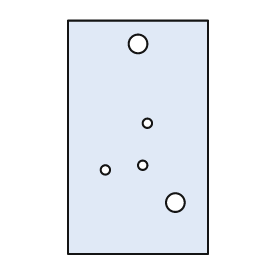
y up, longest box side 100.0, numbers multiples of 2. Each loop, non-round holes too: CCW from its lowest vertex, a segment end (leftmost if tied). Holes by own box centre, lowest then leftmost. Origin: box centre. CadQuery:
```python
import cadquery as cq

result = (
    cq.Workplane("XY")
    .moveTo(-30.0, -50.0)
    .lineTo(30.0, -50.0)
    .lineTo(30.0, 50.0)
    .lineTo(-30.0, 50.0)
    .close()
    .moveTo(16.0, -28.0)
    .circle(4.0)
    .moveTo(-14.0, -14.0)
    .circle(2.0)
    .moveTo(2.0, -12.0)
    .circle(2.0)
    .moveTo(4.0, 6.0)
    .circle(2.0)
    .moveTo(0.0, 40.0)
    .circle(4.0)
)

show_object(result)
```